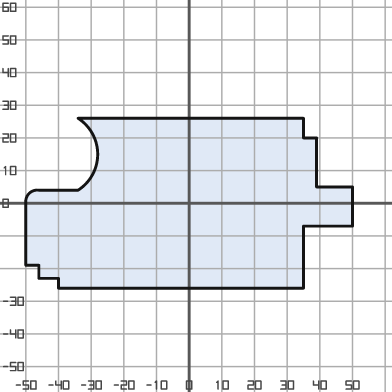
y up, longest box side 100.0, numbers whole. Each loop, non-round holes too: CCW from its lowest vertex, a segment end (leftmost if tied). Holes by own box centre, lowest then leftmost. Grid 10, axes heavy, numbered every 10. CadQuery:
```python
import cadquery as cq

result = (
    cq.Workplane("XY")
    .moveTo(-40.0, -26.0)
    .lineTo(35.0, -26.0)
    .lineTo(35.0, -7.0)
    .lineTo(50.0, -7.0)
    .lineTo(50.0, 5.0)
    .lineTo(39.0, 5.0)
    .lineTo(39.0, 20.0)
    .lineTo(35.0, 20.0)
    .lineTo(35.0, 26.0)
    .lineTo(-34.0, 26.0)
    .threePointArc((-28.0, 15.0), (-34.0, 4.0))
    .lineTo(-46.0, 4.0)
    .threePointArc((-49.0, 3.0), (-50.0, 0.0))
    .lineTo(-50.0, -19.0)
    .lineTo(-46.0, -19.0)
    .lineTo(-46.0, -23.0)
    .lineTo(-40.0, -23.0)
    .close()
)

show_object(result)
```